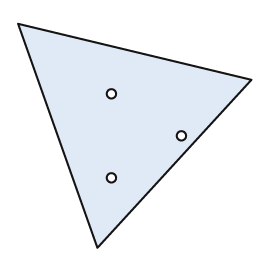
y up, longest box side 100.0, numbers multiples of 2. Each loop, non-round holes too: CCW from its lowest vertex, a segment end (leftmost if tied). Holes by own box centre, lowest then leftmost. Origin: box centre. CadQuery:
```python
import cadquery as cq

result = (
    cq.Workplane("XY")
    .moveTo(-16.0, -48.0)
    .lineTo(50.0, 24.0)
    .lineTo(-50.0, 48.0)
    .close()
    .moveTo(-10.0, -18.0)
    .circle(2.0)
    .moveTo(20.0, 0.0)
    .circle(2.0)
    .moveTo(-10.0, 18.0)
    .circle(2.0)
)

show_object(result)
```